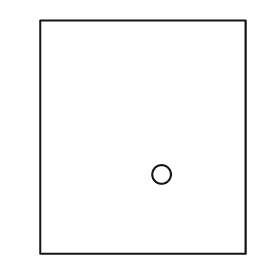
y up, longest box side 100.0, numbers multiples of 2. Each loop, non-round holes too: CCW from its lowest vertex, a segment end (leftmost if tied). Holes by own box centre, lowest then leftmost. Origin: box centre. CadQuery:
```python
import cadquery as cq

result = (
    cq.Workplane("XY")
    .moveTo(-44.0, -50.0)
    .lineTo(44.0, -50.0)
    .lineTo(44.0, 50.0)
    .lineTo(-44.0, 50.0)
    .close()
    .moveTo(8.0, -16.0)
    .circle(4.0)
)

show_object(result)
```